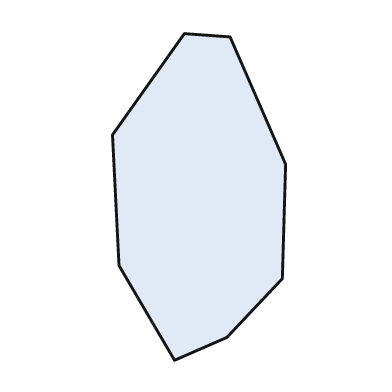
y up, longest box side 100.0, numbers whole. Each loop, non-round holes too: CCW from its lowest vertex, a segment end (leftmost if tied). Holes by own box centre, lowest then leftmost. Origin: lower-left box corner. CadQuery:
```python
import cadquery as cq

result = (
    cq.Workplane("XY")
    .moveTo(19.0, 0.0)
    .lineTo(35.0, 7.0)
    .lineTo(52.0, 25.0)
    .lineTo(53.0, 60.0)
    .lineTo(36.0, 99.0)
    .lineTo(22.0, 100.0)
    .lineTo(0.0, 69.0)
    .lineTo(2.0, 29.0)
    .close()
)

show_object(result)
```